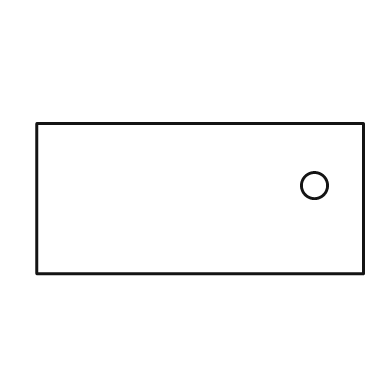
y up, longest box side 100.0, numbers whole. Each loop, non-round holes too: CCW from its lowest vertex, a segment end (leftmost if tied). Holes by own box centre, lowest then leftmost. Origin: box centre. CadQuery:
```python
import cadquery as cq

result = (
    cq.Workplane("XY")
    .moveTo(-50.0, -23.0)
    .lineTo(50.0, -23.0)
    .lineTo(50.0, 23.0)
    .lineTo(-50.0, 23.0)
    .close()
    .moveTo(35.0, 4.0)
    .circle(4.0)
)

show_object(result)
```